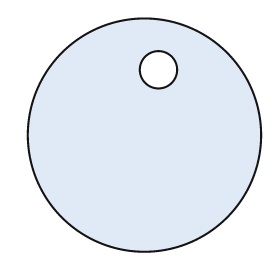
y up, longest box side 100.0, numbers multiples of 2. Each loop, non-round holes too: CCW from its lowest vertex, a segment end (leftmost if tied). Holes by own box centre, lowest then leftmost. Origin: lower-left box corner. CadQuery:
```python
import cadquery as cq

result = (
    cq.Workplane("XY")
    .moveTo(50.0, 50.0)
    .circle(50.0)
    .moveTo(56.0, 78.0)
    .circle(8.0)
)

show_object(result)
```